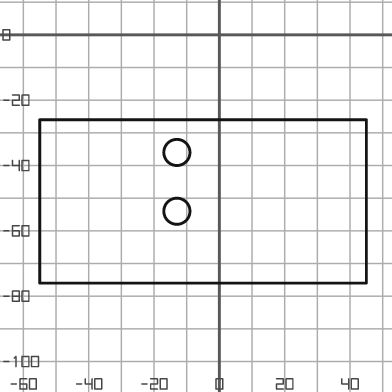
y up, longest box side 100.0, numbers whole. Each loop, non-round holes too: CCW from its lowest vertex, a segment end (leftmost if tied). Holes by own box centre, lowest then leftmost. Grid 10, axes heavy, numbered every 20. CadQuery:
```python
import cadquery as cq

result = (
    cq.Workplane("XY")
    .moveTo(-55.0, -76.0)
    .lineTo(45.0, -76.0)
    .lineTo(45.0, -26.0)
    .lineTo(-55.0, -26.0)
    .close()
    .moveTo(-13.0, -54.0)
    .circle(4.0)
    .moveTo(-13.0, -36.0)
    .circle(4.0)
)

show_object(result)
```